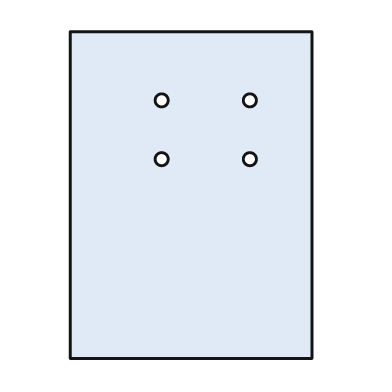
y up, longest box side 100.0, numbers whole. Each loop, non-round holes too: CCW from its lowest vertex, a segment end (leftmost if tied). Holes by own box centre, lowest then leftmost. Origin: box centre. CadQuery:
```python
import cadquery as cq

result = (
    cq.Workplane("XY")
    .moveTo(-37.0, -50.0)
    .lineTo(37.0, -50.0)
    .lineTo(37.0, 50.0)
    .lineTo(-37.0, 50.0)
    .close()
    .moveTo(-9.0, 11.0)
    .circle(2.0)
    .moveTo(18.0, 11.0)
    .circle(2.0)
    .moveTo(-9.0, 29.0)
    .circle(2.0)
    .moveTo(18.0, 29.0)
    .circle(2.0)
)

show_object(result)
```